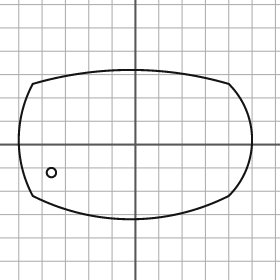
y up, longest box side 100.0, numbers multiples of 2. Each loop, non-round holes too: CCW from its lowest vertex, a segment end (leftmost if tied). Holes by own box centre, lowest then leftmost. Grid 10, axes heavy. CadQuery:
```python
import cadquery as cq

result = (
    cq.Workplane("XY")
    .moveTo(-44.0, -22.0)
    .threePointArc((-2.0, -32.0), (40.0, -22.0))
    .threePointArc((50.0, 2.0), (40.0, 26.0))
    .threePointArc((-2.0, 32.0), (-44.0, 26.0))
    .threePointArc((-50.0, 2.0), (-44.0, -22.0))
    .close()
    .moveTo(-36.0, -12.0)
    .circle(2.0)
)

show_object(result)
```